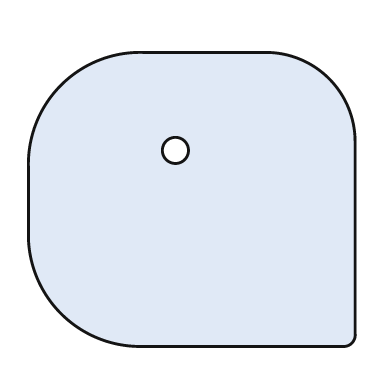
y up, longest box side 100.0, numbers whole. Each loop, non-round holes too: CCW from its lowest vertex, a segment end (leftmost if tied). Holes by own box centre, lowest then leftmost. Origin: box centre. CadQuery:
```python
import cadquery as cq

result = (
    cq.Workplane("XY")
    .moveTo(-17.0, -45.0)
    .lineTo(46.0, -45.0)
    .threePointArc((49.0, -44.0), (50.0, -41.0))
    .lineTo(50.0, 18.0)
    .threePointArc((42.0, 37.0), (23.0, 45.0))
    .lineTo(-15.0, 45.0)
    .threePointArc((-40.0, 35.0), (-50.0, 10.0))
    .lineTo(-50.0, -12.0)
    .threePointArc((-40.0, -35.0), (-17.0, -45.0))
    .close()
    .moveTo(-5.0, 15.0)
    .circle(4.0)
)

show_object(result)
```